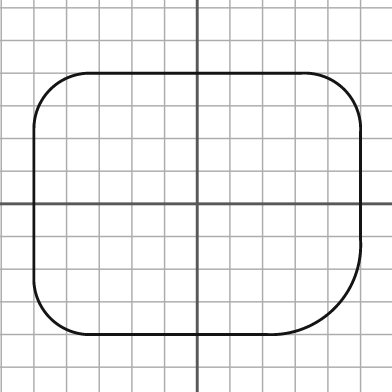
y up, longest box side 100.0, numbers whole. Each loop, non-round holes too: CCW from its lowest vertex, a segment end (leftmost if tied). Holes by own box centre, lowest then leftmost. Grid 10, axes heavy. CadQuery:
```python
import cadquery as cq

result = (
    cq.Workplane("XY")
    .moveTo(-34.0, -40.0)
    .lineTo(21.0, -40.0)
    .threePointArc((42.0, -32.0), (50.0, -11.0))
    .lineTo(50.0, 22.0)
    .threePointArc((45.0, 35.0), (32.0, 40.0))
    .lineTo(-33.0, 40.0)
    .threePointArc((-45.0, 35.0), (-50.0, 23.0))
    .lineTo(-50.0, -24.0)
    .threePointArc((-45.0, -35.0), (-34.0, -40.0))
    .close()
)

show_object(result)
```